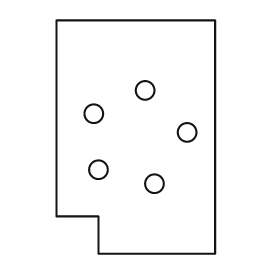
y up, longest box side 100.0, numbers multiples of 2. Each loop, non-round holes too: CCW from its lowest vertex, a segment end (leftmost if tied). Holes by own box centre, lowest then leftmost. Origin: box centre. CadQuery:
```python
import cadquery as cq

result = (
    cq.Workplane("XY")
    .moveTo(-16.0, -50.0)
    .lineTo(34.0, -50.0)
    .lineTo(34.0, 50.0)
    .lineTo(-34.0, 50.0)
    .lineTo(-34.0, -34.0)
    .lineTo(-16.0, -34.0)
    .close()
    .moveTo(8.0, -20.0)
    .circle(4.0)
    .moveTo(-16.0, -14.0)
    .circle(4.0)
    .moveTo(22.0, 2.0)
    .circle(4.0)
    .moveTo(-18.0, 10.0)
    .circle(4.0)
    .moveTo(4.0, 20.0)
    .circle(4.0)
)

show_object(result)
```